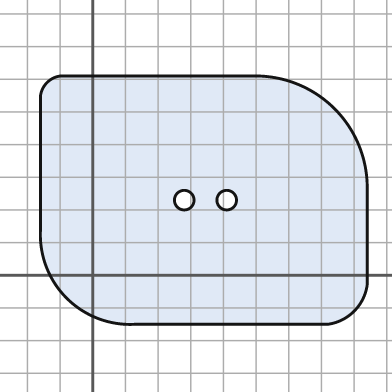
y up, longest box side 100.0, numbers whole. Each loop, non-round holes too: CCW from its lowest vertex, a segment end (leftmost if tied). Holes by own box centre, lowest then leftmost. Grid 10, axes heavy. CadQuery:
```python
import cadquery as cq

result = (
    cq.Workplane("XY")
    .moveTo(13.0, -15.0)
    .lineTo(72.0, -15.0)
    .threePointArc((80.0, -11.0), (84.0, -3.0))
    .lineTo(84.0, 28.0)
    .threePointArc((74.0, 51.0), (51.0, 61.0))
    .lineTo(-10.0, 61.0)
    .threePointArc((-14.0, 59.0), (-16.0, 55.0))
    .lineTo(-16.0, 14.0)
    .threePointArc((-8.0, -7.0), (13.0, -15.0))
    .close()
    .moveTo(28.0, 23.0)
    .circle(3.0)
    .moveTo(41.0, 23.0)
    .circle(3.0)
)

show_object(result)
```